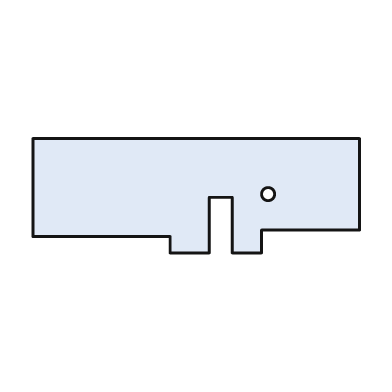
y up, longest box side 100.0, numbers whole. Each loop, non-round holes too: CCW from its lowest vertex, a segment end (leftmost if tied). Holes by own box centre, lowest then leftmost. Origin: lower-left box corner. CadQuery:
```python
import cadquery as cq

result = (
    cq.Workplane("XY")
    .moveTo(42.0, 0.0)
    .lineTo(54.0, 0.0)
    .lineTo(54.0, 17.0)
    .lineTo(61.0, 17.0)
    .lineTo(61.0, 0.0)
    .lineTo(70.0, 0.0)
    .lineTo(70.0, 7.0)
    .lineTo(100.0, 7.0)
    .lineTo(100.0, 35.0)
    .lineTo(0.0, 35.0)
    .lineTo(0.0, 5.0)
    .lineTo(42.0, 5.0)
    .close()
    .moveTo(72.0, 18.0)
    .circle(2.0)
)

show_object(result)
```